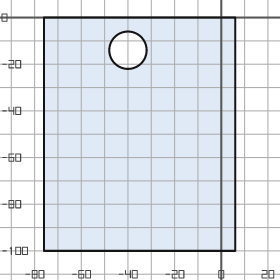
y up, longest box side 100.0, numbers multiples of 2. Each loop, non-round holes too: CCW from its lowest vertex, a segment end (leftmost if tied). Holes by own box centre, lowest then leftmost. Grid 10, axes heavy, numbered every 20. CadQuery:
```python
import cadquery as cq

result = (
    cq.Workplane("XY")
    .moveTo(-76.0, -100.0)
    .lineTo(6.0, -100.0)
    .lineTo(6.0, 0.0)
    .lineTo(-76.0, 0.0)
    .close()
    .moveTo(-40.0, -14.0)
    .circle(8.0)
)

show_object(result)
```